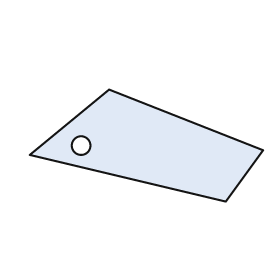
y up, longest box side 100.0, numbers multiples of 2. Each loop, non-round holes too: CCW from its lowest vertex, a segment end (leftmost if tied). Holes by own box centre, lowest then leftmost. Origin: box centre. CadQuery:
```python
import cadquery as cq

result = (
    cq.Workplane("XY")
    .moveTo(34.0, -24.0)
    .lineTo(50.0, -2.0)
    .lineTo(-16.0, 24.0)
    .lineTo(-50.0, -4.0)
    .close()
    .moveTo(-28.0, 0.0)
    .circle(4.0)
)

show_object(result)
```